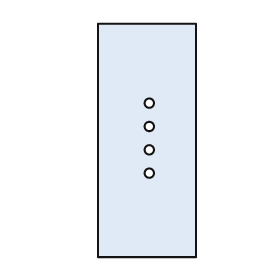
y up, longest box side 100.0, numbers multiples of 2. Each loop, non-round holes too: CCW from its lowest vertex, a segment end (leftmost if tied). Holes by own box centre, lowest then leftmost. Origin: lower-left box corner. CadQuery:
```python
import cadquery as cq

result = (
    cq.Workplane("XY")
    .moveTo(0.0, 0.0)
    .lineTo(42.0, 0.0)
    .lineTo(42.0, 100.0)
    .lineTo(0.0, 100.0)
    .close()
    .moveTo(22.0, 36.0)
    .circle(2.0)
    .moveTo(22.0, 46.0)
    .circle(2.0)
    .moveTo(22.0, 56.0)
    .circle(2.0)
    .moveTo(22.0, 66.0)
    .circle(2.0)
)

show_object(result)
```